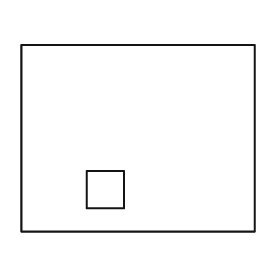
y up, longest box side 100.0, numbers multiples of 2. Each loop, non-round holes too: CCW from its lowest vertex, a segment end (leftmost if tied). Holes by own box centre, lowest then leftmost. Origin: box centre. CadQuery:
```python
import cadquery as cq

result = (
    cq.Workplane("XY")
    .moveTo(-50.0, -40.0)
    .lineTo(50.0, -40.0)
    .lineTo(50.0, 40.0)
    .lineTo(-50.0, 40.0)
    .close()
    .moveTo(-22.0, -30.0)
    .lineTo(-6.0, -30.0)
    .lineTo(-6.0, -14.0)
    .lineTo(-22.0, -14.0)
    .close()
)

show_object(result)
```